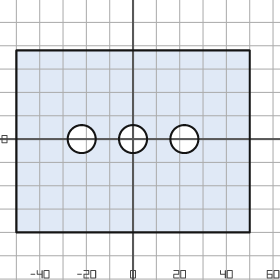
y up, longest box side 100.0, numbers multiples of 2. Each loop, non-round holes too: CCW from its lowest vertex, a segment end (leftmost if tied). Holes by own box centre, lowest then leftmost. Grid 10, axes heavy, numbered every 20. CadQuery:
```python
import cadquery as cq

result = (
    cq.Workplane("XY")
    .moveTo(-50.0, -40.0)
    .lineTo(50.0, -40.0)
    .lineTo(50.0, 38.0)
    .lineTo(-50.0, 38.0)
    .close()
    .moveTo(-22.0, 0.0)
    .circle(6.0)
    .moveTo(0.0, 0.0)
    .circle(6.0)
    .moveTo(22.0, 0.0)
    .circle(6.0)
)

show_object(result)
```